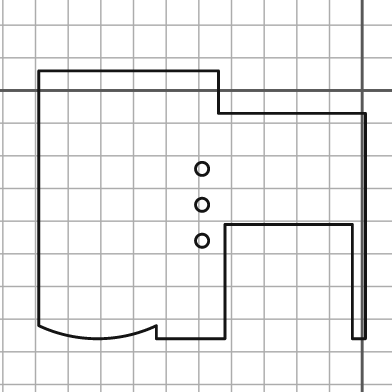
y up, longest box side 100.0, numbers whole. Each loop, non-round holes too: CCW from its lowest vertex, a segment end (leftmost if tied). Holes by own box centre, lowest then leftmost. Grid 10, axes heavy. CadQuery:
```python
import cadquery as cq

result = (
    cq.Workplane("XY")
    .moveTo(-63.0, -76.0)
    .lineTo(-42.0, -76.0)
    .lineTo(-42.0, -41.0)
    .lineTo(-3.0, -41.0)
    .lineTo(-3.0, -76.0)
    .lineTo(1.0, -76.0)
    .lineTo(1.0, -7.0)
    .lineTo(-44.0, -7.0)
    .lineTo(-44.0, 6.0)
    .lineTo(-99.0, 6.0)
    .lineTo(-99.0, -72.0)
    .threePointArc((-81.0, -76.0), (-63.0, -72.0))
    .close()
    .moveTo(-49.0, -46.0)
    .circle(2.0)
    .moveTo(-49.0, -35.0)
    .circle(2.0)
    .moveTo(-49.0, -24.0)
    .circle(2.0)
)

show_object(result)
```